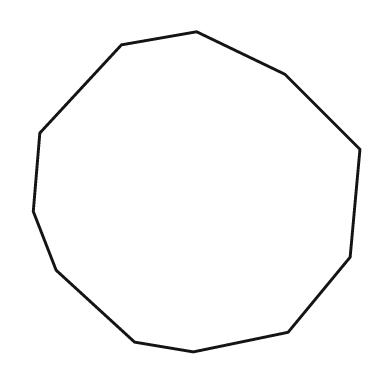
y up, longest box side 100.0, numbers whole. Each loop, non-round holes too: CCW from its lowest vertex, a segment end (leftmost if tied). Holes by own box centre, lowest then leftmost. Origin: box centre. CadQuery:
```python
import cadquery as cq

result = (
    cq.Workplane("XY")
    .moveTo(-1.0, -49.0)
    .lineTo(28.0, -43.0)
    .lineTo(47.0, -20.0)
    .lineTo(50.0, 13.0)
    .lineTo(27.0, 36.0)
    .lineTo(0.0, 49.0)
    .lineTo(-23.0, 45.0)
    .lineTo(-48.0, 18.0)
    .lineTo(-50.0, -6.0)
    .lineTo(-43.0, -24.0)
    .lineTo(-19.0, -46.0)
    .close()
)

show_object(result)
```